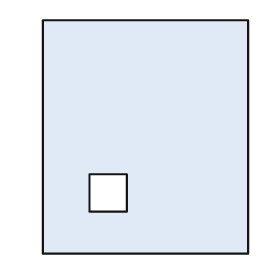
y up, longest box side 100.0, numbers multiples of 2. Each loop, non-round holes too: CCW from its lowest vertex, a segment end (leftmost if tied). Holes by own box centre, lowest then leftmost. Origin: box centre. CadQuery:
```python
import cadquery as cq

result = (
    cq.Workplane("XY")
    .moveTo(-44.0, -50.0)
    .lineTo(44.0, -50.0)
    .lineTo(44.0, 50.0)
    .lineTo(-44.0, 50.0)
    .close()
    .moveTo(-24.0, -32.0)
    .lineTo(-8.0, -32.0)
    .lineTo(-8.0, -16.0)
    .lineTo(-24.0, -16.0)
    .close()
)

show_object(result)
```